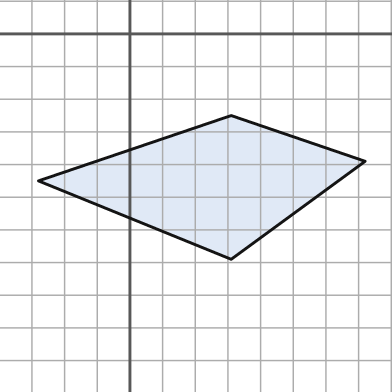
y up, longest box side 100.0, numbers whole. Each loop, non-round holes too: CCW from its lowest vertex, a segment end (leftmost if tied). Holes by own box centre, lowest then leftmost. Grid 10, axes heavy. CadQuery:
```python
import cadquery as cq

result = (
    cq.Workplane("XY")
    .moveTo(31.0, -69.0)
    .lineTo(72.0, -39.0)
    .lineTo(31.0, -25.0)
    .lineTo(-28.0, -45.0)
    .close()
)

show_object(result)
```